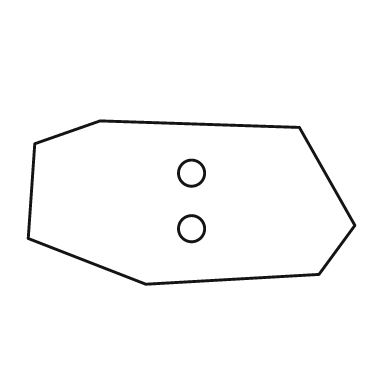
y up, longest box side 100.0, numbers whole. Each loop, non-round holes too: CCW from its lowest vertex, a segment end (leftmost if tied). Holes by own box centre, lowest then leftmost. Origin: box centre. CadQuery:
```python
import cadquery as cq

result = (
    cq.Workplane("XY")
    .moveTo(-14.0, -25.0)
    .lineTo(39.0, -22.0)
    .lineTo(50.0, -7.0)
    .lineTo(33.0, 23.0)
    .lineTo(-28.0, 25.0)
    .lineTo(-48.0, 18.0)
    .lineTo(-50.0, -11.0)
    .close()
    .moveTo(0.0, -8.0)
    .circle(4.0)
    .moveTo(0.0, 9.0)
    .circle(4.0)
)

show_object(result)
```